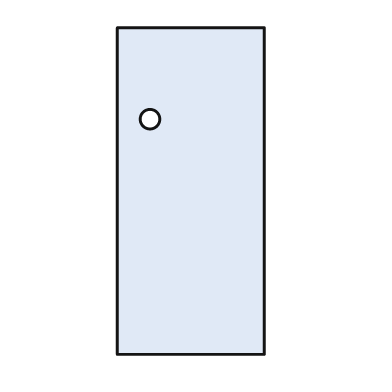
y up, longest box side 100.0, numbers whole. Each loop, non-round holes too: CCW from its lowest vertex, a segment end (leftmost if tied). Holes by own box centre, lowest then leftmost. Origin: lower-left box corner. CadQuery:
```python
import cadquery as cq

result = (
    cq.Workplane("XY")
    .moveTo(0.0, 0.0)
    .lineTo(45.0, 0.0)
    .lineTo(45.0, 100.0)
    .lineTo(0.0, 100.0)
    .close()
    .moveTo(10.0, 72.0)
    .circle(3.0)
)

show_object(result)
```